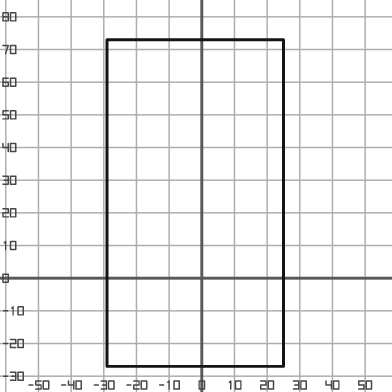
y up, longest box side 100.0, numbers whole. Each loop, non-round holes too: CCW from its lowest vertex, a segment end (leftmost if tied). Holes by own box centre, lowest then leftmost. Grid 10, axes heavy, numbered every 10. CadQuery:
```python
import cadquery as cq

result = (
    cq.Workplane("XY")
    .moveTo(-29.0, -27.0)
    .lineTo(25.0, -27.0)
    .lineTo(25.0, 73.0)
    .lineTo(-29.0, 73.0)
    .close()
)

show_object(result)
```